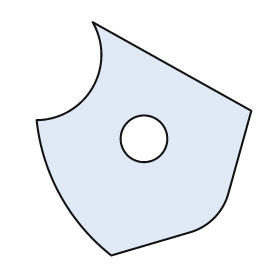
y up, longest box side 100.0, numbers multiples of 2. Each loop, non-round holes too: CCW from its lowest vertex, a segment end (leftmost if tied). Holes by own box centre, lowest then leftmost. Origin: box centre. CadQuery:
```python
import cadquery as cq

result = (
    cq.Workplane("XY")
    .moveTo(-14.0, -50.0)
    .lineTo(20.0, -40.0)
    .threePointArc((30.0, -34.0), (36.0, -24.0))
    .lineTo(46.0, 12.0)
    .lineTo(-22.0, 50.0)
    .threePointArc((-22.0, 22.0), (-46.0, 8.0))
    .threePointArc((-36.0, -24.0), (-14.0, -50.0))
    .close()
    .moveTo(0.0, 0.0)
    .circle(10.0)
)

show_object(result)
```